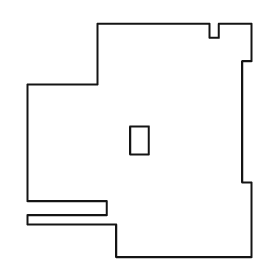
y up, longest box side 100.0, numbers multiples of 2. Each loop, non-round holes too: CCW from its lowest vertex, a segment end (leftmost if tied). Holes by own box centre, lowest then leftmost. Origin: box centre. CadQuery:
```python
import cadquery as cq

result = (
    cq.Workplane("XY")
    .moveTo(-10.0, -50.0)
    .lineTo(48.0, -50.0)
    .lineTo(48.0, -18.0)
    .lineTo(44.0, -18.0)
    .lineTo(44.0, 34.0)
    .lineTo(48.0, 34.0)
    .lineTo(48.0, 50.0)
    .lineTo(34.0, 50.0)
    .lineTo(34.0, 44.0)
    .lineTo(30.0, 44.0)
    .lineTo(30.0, 50.0)
    .lineTo(-18.0, 50.0)
    .lineTo(-18.0, 24.0)
    .lineTo(-48.0, 24.0)
    .lineTo(-48.0, -26.0)
    .lineTo(-14.0, -26.0)
    .lineTo(-14.0, -32.0)
    .lineTo(-48.0, -32.0)
    .lineTo(-48.0, -36.0)
    .lineTo(-10.0, -36.0)
    .close()
    .moveTo(-4.0, -6.0)
    .lineTo(4.0, -6.0)
    .lineTo(4.0, 6.0)
    .lineTo(-4.0, 6.0)
    .close()
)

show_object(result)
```